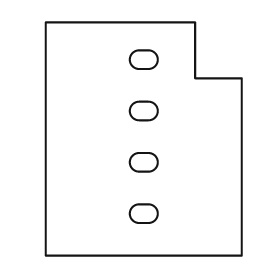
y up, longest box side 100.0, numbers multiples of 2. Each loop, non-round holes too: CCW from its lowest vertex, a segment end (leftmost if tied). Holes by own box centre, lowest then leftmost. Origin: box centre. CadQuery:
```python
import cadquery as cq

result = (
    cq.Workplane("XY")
    .moveTo(-42.0, -50.0)
    .lineTo(42.0, -50.0)
    .lineTo(42.0, 26.0)
    .lineTo(22.0, 26.0)
    .lineTo(22.0, 50.0)
    .lineTo(-42.0, 50.0)
    .close()
    .moveTo(-2.0, -36.0)
    .lineTo(2.0, -36.0)
    .threePointArc((6.0, -32.0), (2.0, -28.0))
    .lineTo(-2.0, -28.0)
    .threePointArc((-6.0, -32.0), (-2.0, -36.0))
    .close()
    .moveTo(-2.0, -14.0)
    .lineTo(2.0, -14.0)
    .threePointArc((6.0, -10.0), (2.0, -6.0))
    .lineTo(-2.0, -6.0)
    .threePointArc((-6.0, -10.0), (-2.0, -14.0))
    .close()
    .moveTo(-2.0, 8.0)
    .lineTo(2.0, 8.0)
    .threePointArc((6.0, 12.0), (2.0, 16.0))
    .lineTo(-2.0, 16.0)
    .threePointArc((-6.0, 12.0), (-2.0, 8.0))
    .close()
    .moveTo(-2.0, 30.0)
    .lineTo(2.0, 30.0)
    .threePointArc((6.0, 34.0), (2.0, 38.0))
    .lineTo(-2.0, 38.0)
    .threePointArc((-6.0, 34.0), (-2.0, 30.0))
    .close()
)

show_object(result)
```